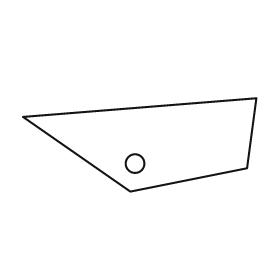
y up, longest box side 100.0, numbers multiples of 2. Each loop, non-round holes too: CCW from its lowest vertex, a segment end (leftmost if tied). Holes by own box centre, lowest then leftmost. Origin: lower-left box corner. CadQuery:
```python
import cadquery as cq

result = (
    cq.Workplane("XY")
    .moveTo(46.0, 0.0)
    .lineTo(96.0, 10.0)
    .lineTo(100.0, 40.0)
    .lineTo(0.0, 32.0)
    .close()
    .moveTo(48.0, 12.0)
    .circle(4.0)
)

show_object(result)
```